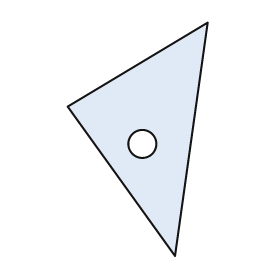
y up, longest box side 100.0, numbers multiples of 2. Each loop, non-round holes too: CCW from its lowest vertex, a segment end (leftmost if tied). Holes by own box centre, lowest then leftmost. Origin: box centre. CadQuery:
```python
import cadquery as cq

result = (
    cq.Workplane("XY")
    .moveTo(16.0, -50.0)
    .lineTo(30.0, 50.0)
    .lineTo(-30.0, 14.0)
    .close()
    .moveTo(2.0, -2.0)
    .circle(6.0)
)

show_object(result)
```